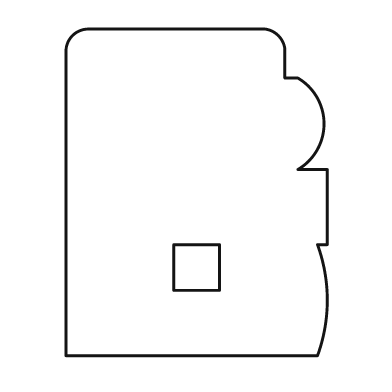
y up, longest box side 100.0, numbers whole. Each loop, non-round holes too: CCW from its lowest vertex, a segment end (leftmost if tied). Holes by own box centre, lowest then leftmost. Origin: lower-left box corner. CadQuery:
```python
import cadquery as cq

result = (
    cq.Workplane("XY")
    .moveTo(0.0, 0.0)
    .lineTo(77.0, 0.0)
    .threePointArc((80.0, 17.0), (77.0, 34.0))
    .lineTo(80.0, 34.0)
    .lineTo(80.0, 57.0)
    .lineTo(71.0, 57.0)
    .threePointArc((79.0, 71.0), (71.0, 85.0))
    .lineTo(67.0, 85.0)
    .lineTo(67.0, 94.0)
    .threePointArc((65.0, 98.0), (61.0, 100.0))
    .lineTo(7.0, 100.0)
    .threePointArc((2.0, 98.0), (0.0, 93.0))
    .close()
    .moveTo(33.0, 20.0)
    .lineTo(47.0, 20.0)
    .lineTo(47.0, 34.0)
    .lineTo(33.0, 34.0)
    .close()
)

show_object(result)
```